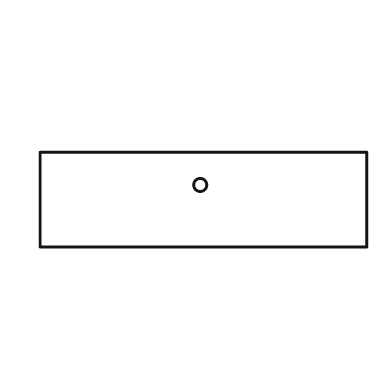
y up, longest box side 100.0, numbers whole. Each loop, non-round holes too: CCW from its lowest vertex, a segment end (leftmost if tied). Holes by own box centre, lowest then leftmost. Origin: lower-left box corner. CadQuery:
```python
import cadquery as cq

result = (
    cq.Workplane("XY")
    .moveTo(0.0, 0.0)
    .lineTo(100.0, 0.0)
    .lineTo(100.0, 29.0)
    .lineTo(0.0, 29.0)
    .close()
    .moveTo(49.0, 19.0)
    .circle(2.0)
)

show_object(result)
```